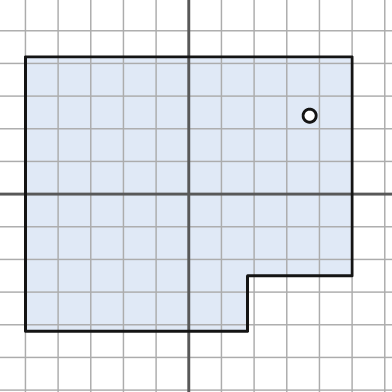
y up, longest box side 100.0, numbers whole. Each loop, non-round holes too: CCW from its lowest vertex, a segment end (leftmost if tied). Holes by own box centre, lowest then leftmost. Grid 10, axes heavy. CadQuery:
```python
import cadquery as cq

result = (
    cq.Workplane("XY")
    .moveTo(-50.0, -42.0)
    .lineTo(18.0, -42.0)
    .lineTo(18.0, -25.0)
    .lineTo(50.0, -25.0)
    .lineTo(50.0, 42.0)
    .lineTo(-50.0, 42.0)
    .close()
    .moveTo(37.0, 24.0)
    .circle(2.0)
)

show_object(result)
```